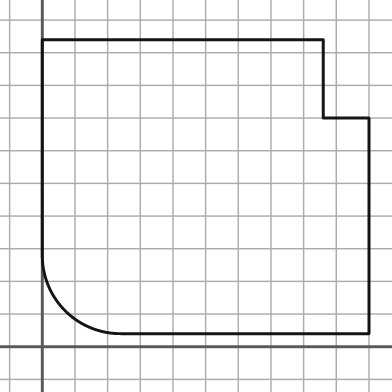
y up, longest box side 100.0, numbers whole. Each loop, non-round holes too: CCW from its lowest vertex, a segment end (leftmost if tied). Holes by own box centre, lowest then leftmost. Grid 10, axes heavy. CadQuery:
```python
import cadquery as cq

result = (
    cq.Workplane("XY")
    .moveTo(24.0, 4.0)
    .lineTo(100.0, 4.0)
    .lineTo(100.0, 70.0)
    .lineTo(86.0, 70.0)
    .lineTo(86.0, 94.0)
    .lineTo(0.0, 94.0)
    .lineTo(0.0, 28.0)
    .threePointArc((7.0, 11.0), (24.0, 4.0))
    .close()
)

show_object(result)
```